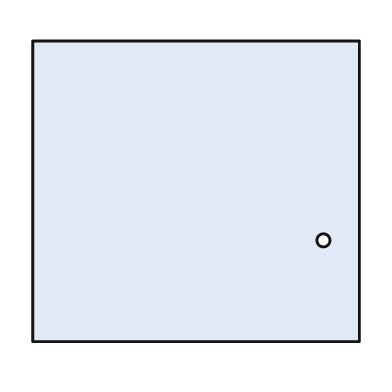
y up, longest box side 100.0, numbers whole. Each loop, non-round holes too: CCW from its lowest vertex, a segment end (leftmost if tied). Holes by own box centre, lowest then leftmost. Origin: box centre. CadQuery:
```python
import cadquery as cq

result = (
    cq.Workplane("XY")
    .moveTo(-50.0, -46.0)
    .lineTo(50.0, -46.0)
    .lineTo(50.0, 46.0)
    .lineTo(-50.0, 46.0)
    .close()
    .moveTo(39.0, -15.0)
    .circle(2.0)
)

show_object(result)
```